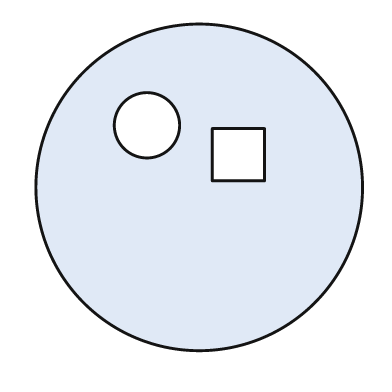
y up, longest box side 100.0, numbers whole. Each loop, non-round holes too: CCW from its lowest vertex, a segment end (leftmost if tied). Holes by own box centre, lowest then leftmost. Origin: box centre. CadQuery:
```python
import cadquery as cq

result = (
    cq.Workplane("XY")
    .moveTo(0.0, 0.0)
    .circle(50.0)
    .moveTo(4.0, 2.0)
    .lineTo(20.0, 2.0)
    .lineTo(20.0, 18.0)
    .lineTo(4.0, 18.0)
    .close()
    .moveTo(-16.0, 19.0)
    .circle(10.0)
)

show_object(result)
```